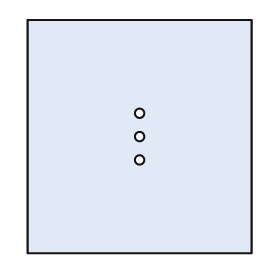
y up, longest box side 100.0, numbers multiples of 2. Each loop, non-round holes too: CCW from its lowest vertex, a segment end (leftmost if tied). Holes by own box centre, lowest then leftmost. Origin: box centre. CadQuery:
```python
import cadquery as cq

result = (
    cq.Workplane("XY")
    .moveTo(-48.0, -50.0)
    .lineTo(48.0, -50.0)
    .lineTo(48.0, 50.0)
    .lineTo(-48.0, 50.0)
    .close()
    .moveTo(0.0, -10.0)
    .circle(2.0)
    .moveTo(0.0, 0.0)
    .circle(2.0)
    .moveTo(0.0, 10.0)
    .circle(2.0)
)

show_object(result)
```